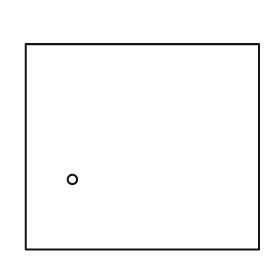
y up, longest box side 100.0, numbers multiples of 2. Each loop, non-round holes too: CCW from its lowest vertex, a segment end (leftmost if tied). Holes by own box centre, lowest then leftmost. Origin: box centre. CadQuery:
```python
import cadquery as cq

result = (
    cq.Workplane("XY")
    .moveTo(-50.0, -44.0)
    .lineTo(50.0, -44.0)
    .lineTo(50.0, 44.0)
    .lineTo(-50.0, 44.0)
    .close()
    .moveTo(-30.0, -14.0)
    .circle(2.0)
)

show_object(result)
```